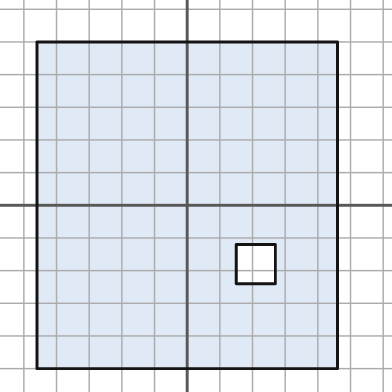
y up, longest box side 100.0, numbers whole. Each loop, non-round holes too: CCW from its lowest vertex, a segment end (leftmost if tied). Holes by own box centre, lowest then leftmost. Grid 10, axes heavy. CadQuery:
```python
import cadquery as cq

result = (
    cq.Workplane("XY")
    .moveTo(-46.0, -50.0)
    .lineTo(46.0, -50.0)
    .lineTo(46.0, 50.0)
    .lineTo(-46.0, 50.0)
    .close()
    .moveTo(15.0, -24.0)
    .lineTo(27.0, -24.0)
    .lineTo(27.0, -12.0)
    .lineTo(15.0, -12.0)
    .close()
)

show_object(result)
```